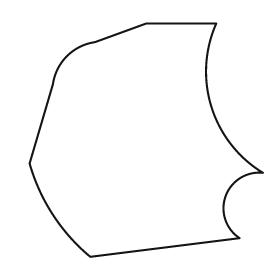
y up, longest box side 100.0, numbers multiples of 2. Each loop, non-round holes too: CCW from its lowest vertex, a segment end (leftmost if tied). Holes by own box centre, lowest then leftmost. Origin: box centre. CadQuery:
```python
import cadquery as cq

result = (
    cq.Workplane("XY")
    .moveTo(-24.0, -50.0)
    .lineTo(40.0, -42.0)
    .threePointArc((34.0, -24.0), (50.0, -14.0))
    .threePointArc((28.0, 14.0), (30.0, 50.0))
    .lineTo(0.0, 50.0)
    .lineTo(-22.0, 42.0)
    .threePointArc((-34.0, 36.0), (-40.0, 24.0))
    .lineTo(-50.0, -10.0)
    .threePointArc((-40.0, -32.0), (-24.0, -50.0))
    .close()
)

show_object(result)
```